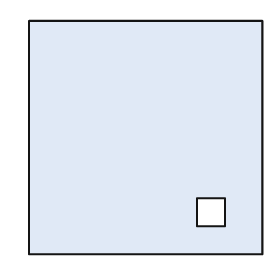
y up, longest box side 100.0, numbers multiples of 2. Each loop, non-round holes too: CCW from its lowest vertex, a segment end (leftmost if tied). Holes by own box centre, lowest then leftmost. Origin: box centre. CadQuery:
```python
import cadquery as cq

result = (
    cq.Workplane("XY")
    .moveTo(-50.0, -50.0)
    .lineTo(50.0, -50.0)
    .lineTo(50.0, 50.0)
    .lineTo(-50.0, 50.0)
    .close()
    .moveTo(22.0, -38.0)
    .lineTo(34.0, -38.0)
    .lineTo(34.0, -26.0)
    .lineTo(22.0, -26.0)
    .close()
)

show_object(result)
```